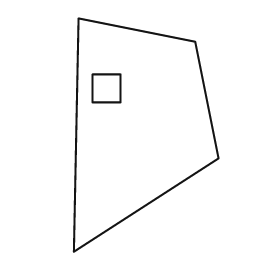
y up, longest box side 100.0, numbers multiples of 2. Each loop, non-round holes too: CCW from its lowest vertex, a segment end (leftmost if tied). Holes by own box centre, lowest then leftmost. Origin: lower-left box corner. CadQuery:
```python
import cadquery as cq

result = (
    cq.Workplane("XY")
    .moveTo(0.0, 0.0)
    .lineTo(62.0, 40.0)
    .lineTo(52.0, 90.0)
    .lineTo(2.0, 100.0)
    .close()
    .moveTo(8.0, 64.0)
    .lineTo(20.0, 64.0)
    .lineTo(20.0, 76.0)
    .lineTo(8.0, 76.0)
    .close()
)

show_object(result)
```